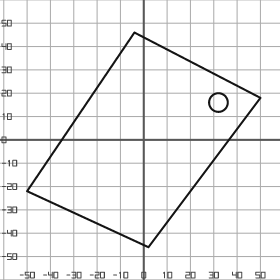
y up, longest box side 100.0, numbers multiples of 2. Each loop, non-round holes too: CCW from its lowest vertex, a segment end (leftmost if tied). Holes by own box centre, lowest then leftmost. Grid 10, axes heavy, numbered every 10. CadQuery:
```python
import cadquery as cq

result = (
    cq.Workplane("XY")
    .moveTo(2.0, -46.0)
    .lineTo(50.0, 18.0)
    .lineTo(-4.0, 46.0)
    .lineTo(-50.0, -22.0)
    .close()
    .moveTo(32.0, 16.0)
    .circle(4.0)
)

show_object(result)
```